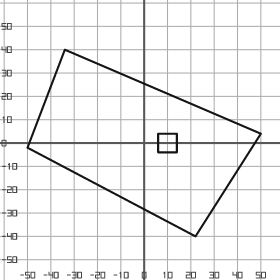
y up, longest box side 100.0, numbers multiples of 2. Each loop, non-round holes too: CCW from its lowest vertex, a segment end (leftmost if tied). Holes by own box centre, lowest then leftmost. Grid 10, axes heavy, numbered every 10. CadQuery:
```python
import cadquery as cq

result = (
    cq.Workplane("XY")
    .moveTo(22.0, -40.0)
    .lineTo(50.0, 4.0)
    .lineTo(-34.0, 40.0)
    .lineTo(-50.0, -2.0)
    .close()
    .moveTo(6.0, -4.0)
    .lineTo(14.0, -4.0)
    .lineTo(14.0, 4.0)
    .lineTo(6.0, 4.0)
    .close()
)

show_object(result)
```